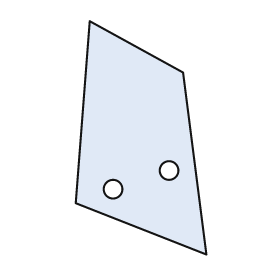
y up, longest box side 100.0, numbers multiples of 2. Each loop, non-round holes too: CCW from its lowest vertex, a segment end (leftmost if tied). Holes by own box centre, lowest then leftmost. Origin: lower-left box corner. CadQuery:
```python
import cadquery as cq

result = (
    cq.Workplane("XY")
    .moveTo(56.0, 0.0)
    .lineTo(46.0, 78.0)
    .lineTo(6.0, 100.0)
    .lineTo(0.0, 22.0)
    .close()
    .moveTo(16.0, 28.0)
    .circle(4.0)
    .moveTo(40.0, 36.0)
    .circle(4.0)
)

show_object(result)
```